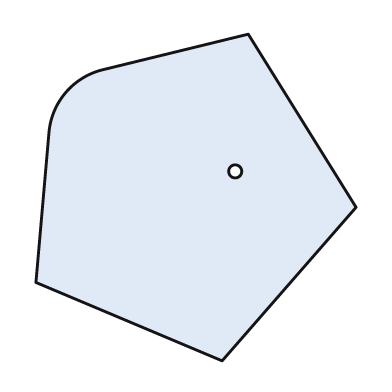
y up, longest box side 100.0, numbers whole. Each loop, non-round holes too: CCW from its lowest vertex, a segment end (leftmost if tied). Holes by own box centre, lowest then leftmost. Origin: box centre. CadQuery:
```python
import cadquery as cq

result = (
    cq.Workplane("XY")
    .moveTo(8.0, -50.0)
    .lineTo(49.0, -3.0)
    .lineTo(16.0, 50.0)
    .lineTo(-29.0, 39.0)
    .threePointArc((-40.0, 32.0), (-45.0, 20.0))
    .lineTo(-49.0, -26.0)
    .close()
    .moveTo(12.0, 8.0)
    .circle(2.0)
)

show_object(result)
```